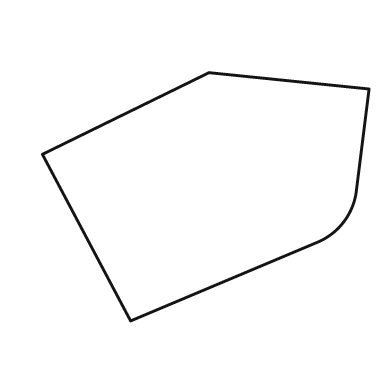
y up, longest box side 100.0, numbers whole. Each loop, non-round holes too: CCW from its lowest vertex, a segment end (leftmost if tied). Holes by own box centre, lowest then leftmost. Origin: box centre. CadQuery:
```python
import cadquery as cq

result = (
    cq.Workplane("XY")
    .moveTo(-23.0, -38.0)
    .lineTo(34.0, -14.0)
    .threePointArc((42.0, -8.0), (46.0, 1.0))
    .lineTo(50.0, 33.0)
    .lineTo(1.0, 38.0)
    .lineTo(-50.0, 13.0)
    .close()
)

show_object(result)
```